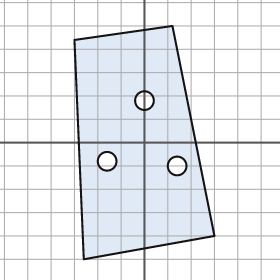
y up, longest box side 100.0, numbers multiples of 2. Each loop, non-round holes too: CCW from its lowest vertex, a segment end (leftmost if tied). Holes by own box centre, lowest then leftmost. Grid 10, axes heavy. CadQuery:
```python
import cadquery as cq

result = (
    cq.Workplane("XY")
    .moveTo(-26.0, -50.0)
    .lineTo(30.0, -40.0)
    .lineTo(12.0, 50.0)
    .lineTo(-30.0, 44.0)
    .close()
    .moveTo(14.0, -10.0)
    .circle(4.0)
    .moveTo(-16.0, -8.0)
    .circle(4.0)
    .moveTo(0.0, 18.0)
    .circle(4.0)
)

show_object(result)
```